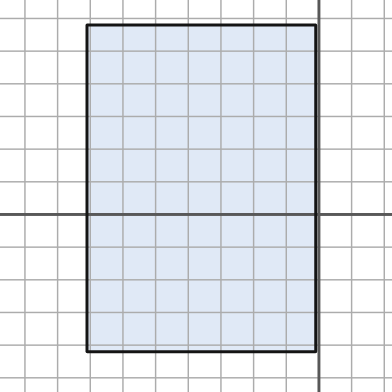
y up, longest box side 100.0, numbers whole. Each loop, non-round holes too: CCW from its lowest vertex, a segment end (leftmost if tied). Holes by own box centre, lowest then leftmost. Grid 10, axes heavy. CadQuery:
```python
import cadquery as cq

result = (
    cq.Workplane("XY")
    .moveTo(-71.0, -42.0)
    .lineTo(-1.0, -42.0)
    .lineTo(-1.0, 58.0)
    .lineTo(-71.0, 58.0)
    .close()
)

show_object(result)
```